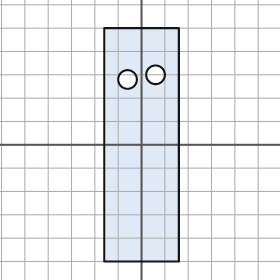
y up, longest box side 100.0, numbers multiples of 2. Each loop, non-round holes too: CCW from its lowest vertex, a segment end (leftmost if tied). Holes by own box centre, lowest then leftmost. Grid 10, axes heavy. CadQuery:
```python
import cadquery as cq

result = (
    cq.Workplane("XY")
    .moveTo(-16.0, -50.0)
    .lineTo(16.0, -50.0)
    .lineTo(16.0, 50.0)
    .lineTo(-16.0, 50.0)
    .close()
    .moveTo(-6.0, 28.0)
    .circle(4.0)
    .moveTo(6.0, 30.0)
    .circle(4.0)
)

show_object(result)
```